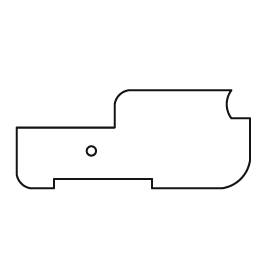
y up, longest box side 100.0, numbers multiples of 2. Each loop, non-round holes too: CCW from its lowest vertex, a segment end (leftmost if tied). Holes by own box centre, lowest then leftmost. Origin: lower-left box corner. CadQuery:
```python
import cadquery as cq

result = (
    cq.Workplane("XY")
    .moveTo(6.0, 0.0)
    .lineTo(16.0, 0.0)
    .lineTo(16.0, 4.0)
    .lineTo(58.0, 4.0)
    .lineTo(58.0, 0.0)
    .lineTo(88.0, 0.0)
    .threePointArc((96.0, 4.0), (100.0, 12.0))
    .lineTo(100.0, 30.0)
    .lineTo(92.0, 30.0)
    .threePointArc((90.0, 36.0), (92.0, 42.0))
    .lineTo(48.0, 42.0)
    .threePointArc((44.0, 40.0), (42.0, 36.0))
    .lineTo(42.0, 26.0)
    .lineTo(0.0, 26.0)
    .lineTo(0.0, 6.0)
    .threePointArc((2.0, 2.0), (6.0, 0.0))
    .close()
    .moveTo(32.0, 16.0)
    .circle(2.0)
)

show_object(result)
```